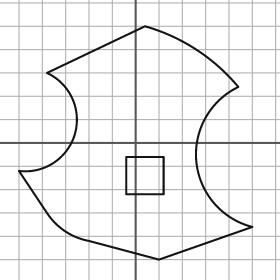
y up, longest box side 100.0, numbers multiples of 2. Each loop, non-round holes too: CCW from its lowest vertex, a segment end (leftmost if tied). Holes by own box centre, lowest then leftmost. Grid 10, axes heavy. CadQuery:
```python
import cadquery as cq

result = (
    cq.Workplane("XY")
    .moveTo(10.0, -50.0)
    .lineTo(50.0, -36.0)
    .threePointArc((26.0, -8.0), (44.0, 24.0))
    .threePointArc((26.0, 40.0), (4.0, 50.0))
    .lineTo(-38.0, 30.0)
    .threePointArc((-26.0, 4.0), (-50.0, -12.0))
    .lineTo(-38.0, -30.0)
    .threePointArc((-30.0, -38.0), (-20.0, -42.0))
    .close()
    .moveTo(-4.0, -22.0)
    .lineTo(12.0, -22.0)
    .lineTo(12.0, -6.0)
    .lineTo(-4.0, -6.0)
    .close()
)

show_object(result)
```